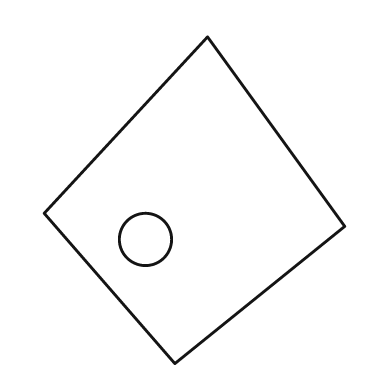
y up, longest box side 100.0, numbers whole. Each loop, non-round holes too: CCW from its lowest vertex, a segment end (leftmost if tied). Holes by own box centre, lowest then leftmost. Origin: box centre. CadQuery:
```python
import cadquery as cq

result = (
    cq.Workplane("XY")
    .moveTo(-6.0, -50.0)
    .lineTo(46.0, -8.0)
    .lineTo(4.0, 50.0)
    .lineTo(-46.0, -4.0)
    .close()
    .moveTo(-15.0, -12.0)
    .circle(8.0)
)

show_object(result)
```